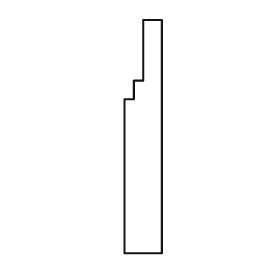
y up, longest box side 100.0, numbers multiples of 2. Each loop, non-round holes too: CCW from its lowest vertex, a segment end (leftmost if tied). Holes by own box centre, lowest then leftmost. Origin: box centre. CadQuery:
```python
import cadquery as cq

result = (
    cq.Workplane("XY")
    .moveTo(-8.0, -50.0)
    .lineTo(8.0, -50.0)
    .lineTo(8.0, 50.0)
    .lineTo(0.0, 50.0)
    .lineTo(0.0, 24.0)
    .lineTo(-4.0, 24.0)
    .lineTo(-4.0, 16.0)
    .lineTo(-8.0, 16.0)
    .close()
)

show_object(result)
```